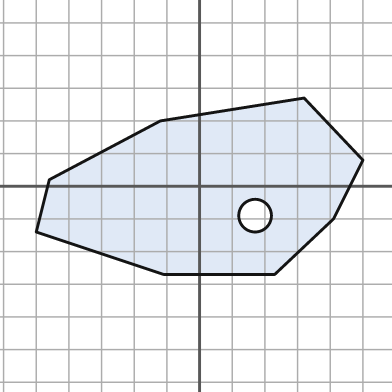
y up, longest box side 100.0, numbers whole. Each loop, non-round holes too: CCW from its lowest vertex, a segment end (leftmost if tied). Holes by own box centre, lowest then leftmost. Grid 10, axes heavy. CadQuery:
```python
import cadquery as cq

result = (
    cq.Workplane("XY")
    .moveTo(-11.0, -27.0)
    .lineTo(23.0, -27.0)
    .lineTo(41.0, -10.0)
    .lineTo(50.0, 8.0)
    .lineTo(32.0, 27.0)
    .lineTo(-12.0, 20.0)
    .lineTo(-46.0, 2.0)
    .lineTo(-50.0, -14.0)
    .close()
    .moveTo(17.0, -9.0)
    .circle(5.0)
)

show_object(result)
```